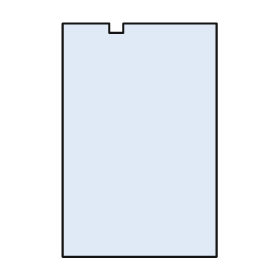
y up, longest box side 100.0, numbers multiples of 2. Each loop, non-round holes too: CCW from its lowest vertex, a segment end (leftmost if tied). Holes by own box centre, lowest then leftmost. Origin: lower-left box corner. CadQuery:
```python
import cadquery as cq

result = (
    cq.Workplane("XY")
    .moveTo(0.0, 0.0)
    .lineTo(66.0, 0.0)
    .lineTo(66.0, 100.0)
    .lineTo(26.0, 100.0)
    .lineTo(26.0, 96.0)
    .lineTo(20.0, 96.0)
    .lineTo(20.0, 100.0)
    .lineTo(0.0, 100.0)
    .close()
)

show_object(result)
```